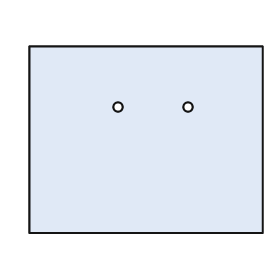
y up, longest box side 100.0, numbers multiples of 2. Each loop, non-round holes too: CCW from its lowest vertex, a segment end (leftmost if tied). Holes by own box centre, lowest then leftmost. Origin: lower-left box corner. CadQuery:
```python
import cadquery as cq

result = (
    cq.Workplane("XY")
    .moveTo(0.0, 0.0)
    .lineTo(100.0, 0.0)
    .lineTo(100.0, 80.0)
    .lineTo(0.0, 80.0)
    .close()
    .moveTo(38.0, 54.0)
    .circle(2.0)
    .moveTo(68.0, 54.0)
    .circle(2.0)
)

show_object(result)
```